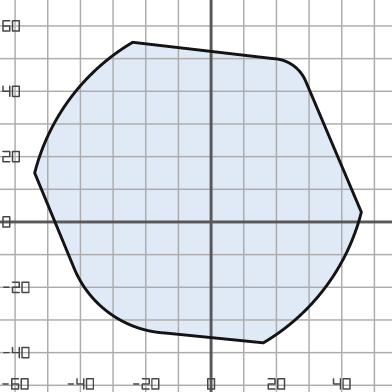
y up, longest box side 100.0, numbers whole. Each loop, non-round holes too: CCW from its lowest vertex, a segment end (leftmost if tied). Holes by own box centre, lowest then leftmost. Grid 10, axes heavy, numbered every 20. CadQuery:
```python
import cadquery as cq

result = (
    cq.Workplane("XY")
    .moveTo(16.0, -37.0)
    .threePointArc((35.0, -20.0), (46.0, 3.0))
    .lineTo(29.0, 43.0)
    .threePointArc((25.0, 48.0), (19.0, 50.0))
    .lineTo(-24.0, 55.0)
    .threePointArc((-43.0, 38.0), (-54.0, 15.0))
    .lineTo(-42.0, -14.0)
    .threePointArc((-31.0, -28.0), (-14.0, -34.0))
    .close()
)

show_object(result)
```